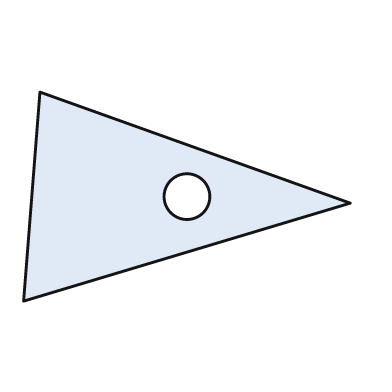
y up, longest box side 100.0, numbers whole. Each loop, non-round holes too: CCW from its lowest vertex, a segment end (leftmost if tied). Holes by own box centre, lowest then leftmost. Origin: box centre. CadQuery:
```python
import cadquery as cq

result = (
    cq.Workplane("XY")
    .moveTo(-50.0, -32.0)
    .lineTo(50.0, -2.0)
    .lineTo(-45.0, 32.0)
    .close()
    .moveTo(0.0, 0.0)
    .circle(7.0)
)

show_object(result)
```